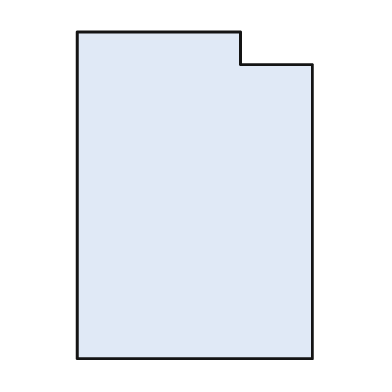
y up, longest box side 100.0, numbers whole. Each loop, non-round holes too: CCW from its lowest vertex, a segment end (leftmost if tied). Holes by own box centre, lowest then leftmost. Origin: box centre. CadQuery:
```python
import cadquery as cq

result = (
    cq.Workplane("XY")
    .moveTo(-36.0, -50.0)
    .lineTo(36.0, -50.0)
    .lineTo(36.0, 40.0)
    .lineTo(14.0, 40.0)
    .lineTo(14.0, 50.0)
    .lineTo(-36.0, 50.0)
    .close()
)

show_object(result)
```